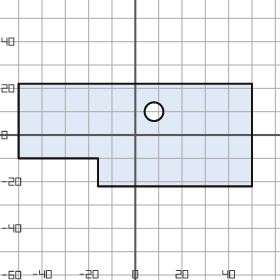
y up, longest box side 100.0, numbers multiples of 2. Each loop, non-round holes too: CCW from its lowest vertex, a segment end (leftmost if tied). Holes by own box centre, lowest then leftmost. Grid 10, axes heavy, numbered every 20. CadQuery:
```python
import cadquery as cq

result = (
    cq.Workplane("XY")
    .moveTo(-16.0, -22.0)
    .lineTo(50.0, -22.0)
    .lineTo(50.0, 22.0)
    .lineTo(-50.0, 22.0)
    .lineTo(-50.0, -10.0)
    .lineTo(-16.0, -10.0)
    .close()
    .moveTo(8.0, 10.0)
    .circle(4.0)
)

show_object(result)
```